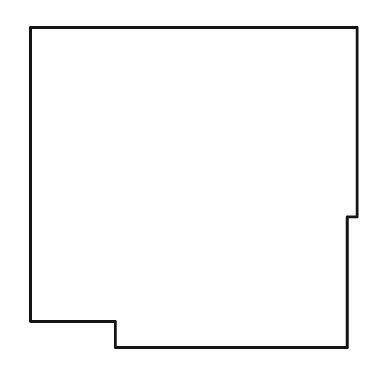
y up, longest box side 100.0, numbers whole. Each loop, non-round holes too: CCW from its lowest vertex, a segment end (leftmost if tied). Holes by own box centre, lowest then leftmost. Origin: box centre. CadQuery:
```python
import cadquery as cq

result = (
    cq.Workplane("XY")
    .moveTo(-24.0, -49.0)
    .lineTo(47.0, -49.0)
    .lineTo(47.0, -9.0)
    .lineTo(50.0, -9.0)
    .lineTo(50.0, 49.0)
    .lineTo(-50.0, 49.0)
    .lineTo(-50.0, -41.0)
    .lineTo(-24.0, -41.0)
    .close()
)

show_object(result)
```